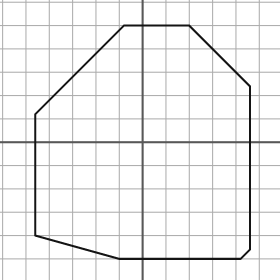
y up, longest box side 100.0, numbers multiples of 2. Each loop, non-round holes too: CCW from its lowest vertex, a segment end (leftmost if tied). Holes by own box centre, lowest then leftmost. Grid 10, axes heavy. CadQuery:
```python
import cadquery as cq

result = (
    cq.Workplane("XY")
    .moveTo(-10.0, -50.0)
    .lineTo(42.0, -50.0)
    .lineTo(46.0, -46.0)
    .lineTo(46.0, 24.0)
    .lineTo(20.0, 50.0)
    .lineTo(-8.0, 50.0)
    .lineTo(-46.0, 12.0)
    .lineTo(-46.0, -40.0)
    .close()
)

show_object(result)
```